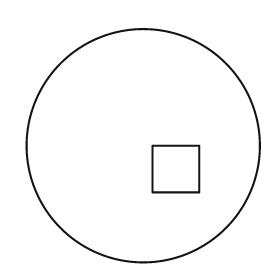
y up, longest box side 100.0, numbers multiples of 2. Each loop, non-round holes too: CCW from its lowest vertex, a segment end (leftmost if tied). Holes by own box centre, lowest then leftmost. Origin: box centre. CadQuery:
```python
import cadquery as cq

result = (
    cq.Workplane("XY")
    .moveTo(0.0, 0.0)
    .circle(50.0)
    .moveTo(4.0, -20.0)
    .lineTo(24.0, -20.0)
    .lineTo(24.0, 0.0)
    .lineTo(4.0, 0.0)
    .close()
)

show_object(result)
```